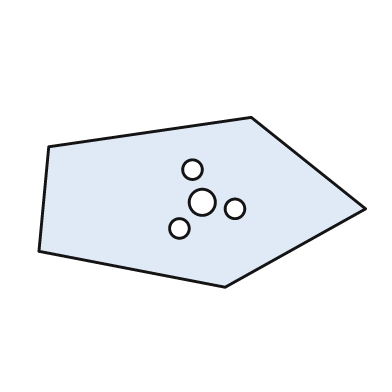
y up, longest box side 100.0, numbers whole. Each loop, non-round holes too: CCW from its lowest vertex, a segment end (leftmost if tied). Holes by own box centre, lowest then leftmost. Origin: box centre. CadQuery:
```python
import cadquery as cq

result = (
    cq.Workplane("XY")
    .moveTo(7.0, -26.0)
    .lineTo(50.0, -2.0)
    .lineTo(15.0, 26.0)
    .lineTo(-47.0, 17.0)
    .lineTo(-50.0, -15.0)
    .close()
    .moveTo(-7.0, -8.0)
    .circle(3.0)
    .moveTo(10.0, -2.0)
    .circle(3.0)
    .moveTo(0.0, 0.0)
    .circle(4.0)
    .moveTo(-3.0, 10.0)
    .circle(3.0)
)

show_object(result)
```